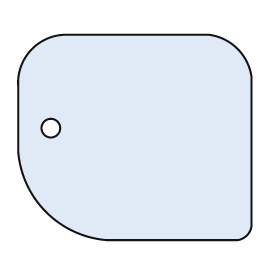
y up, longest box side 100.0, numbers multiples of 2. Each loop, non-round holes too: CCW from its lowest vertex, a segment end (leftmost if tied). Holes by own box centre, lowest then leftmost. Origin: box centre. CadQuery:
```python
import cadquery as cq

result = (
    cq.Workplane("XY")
    .moveTo(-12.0, -44.0)
    .lineTo(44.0, -44.0)
    .threePointArc((48.0, -42.0), (50.0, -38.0))
    .lineTo(50.0, 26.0)
    .threePointArc((44.0, 38.0), (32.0, 44.0))
    .lineTo(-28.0, 44.0)
    .threePointArc((-44.0, 38.0), (-50.0, 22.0))
    .lineTo(-50.0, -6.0)
    .threePointArc((-38.0, -32.0), (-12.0, -44.0))
    .close()
    .moveTo(-36.0, 4.0)
    .circle(4.0)
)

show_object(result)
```